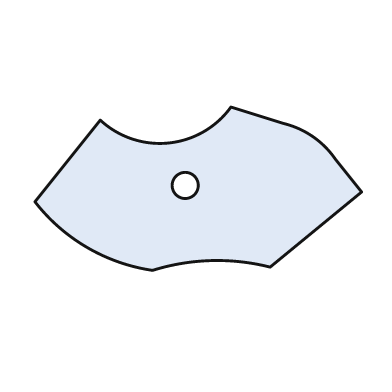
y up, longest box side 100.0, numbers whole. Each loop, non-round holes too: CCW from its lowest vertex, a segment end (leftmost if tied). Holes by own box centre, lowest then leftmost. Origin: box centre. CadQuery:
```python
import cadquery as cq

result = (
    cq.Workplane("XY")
    .moveTo(-14.0, -25.0)
    .threePointArc((4.0, -22.0), (22.0, -24.0))
    .lineTo(50.0, -1.0)
    .lineTo(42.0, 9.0)
    .threePointArc((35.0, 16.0), (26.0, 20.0))
    .lineTo(10.0, 25.0)
    .threePointArc((-9.0, 14.0), (-30.0, 21.0))
    .lineTo(-50.0, -4.0)
    .threePointArc((-34.0, -18.0), (-14.0, -25.0))
    .close()
    .moveTo(-4.0, 1.0)
    .circle(4.0)
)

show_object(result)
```